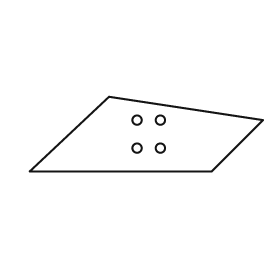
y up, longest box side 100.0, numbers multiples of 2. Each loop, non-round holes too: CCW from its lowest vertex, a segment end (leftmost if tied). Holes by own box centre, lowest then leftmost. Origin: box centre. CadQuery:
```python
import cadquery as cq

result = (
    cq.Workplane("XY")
    .moveTo(-50.0, -16.0)
    .lineTo(28.0, -16.0)
    .lineTo(50.0, 6.0)
    .lineTo(-16.0, 16.0)
    .close()
    .moveTo(-4.0, -6.0)
    .circle(2.0)
    .moveTo(6.0, -6.0)
    .circle(2.0)
    .moveTo(-4.0, 6.0)
    .circle(2.0)
    .moveTo(6.0, 6.0)
    .circle(2.0)
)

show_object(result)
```